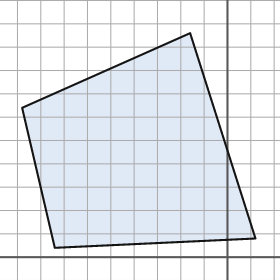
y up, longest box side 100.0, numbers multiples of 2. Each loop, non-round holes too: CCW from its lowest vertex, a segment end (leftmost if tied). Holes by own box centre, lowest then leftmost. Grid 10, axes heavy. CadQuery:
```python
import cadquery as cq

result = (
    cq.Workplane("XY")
    .moveTo(-74.0, 4.0)
    .lineTo(12.0, 8.0)
    .lineTo(-16.0, 96.0)
    .lineTo(-88.0, 64.0)
    .close()
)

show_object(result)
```